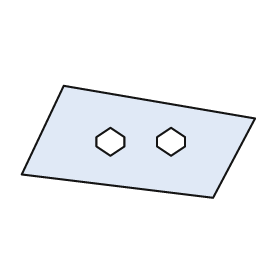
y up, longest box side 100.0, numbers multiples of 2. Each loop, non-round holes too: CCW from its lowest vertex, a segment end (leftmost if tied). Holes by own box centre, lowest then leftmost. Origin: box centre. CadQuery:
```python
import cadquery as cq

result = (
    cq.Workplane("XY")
    .moveTo(32.0, -24.0)
    .lineTo(50.0, 10.0)
    .lineTo(-32.0, 24.0)
    .lineTo(-50.0, -14.0)
    .close()
    .moveTo(-12.0, -6.0)
    .lineTo(-6.0, -2.0)
    .lineTo(-6.0, 2.0)
    .lineTo(-12.0, 6.0)
    .lineTo(-18.0, 2.0)
    .lineTo(-18.0, -2.0)
    .close()
    .moveTo(14.0, -6.0)
    .lineTo(20.0, -2.0)
    .lineTo(20.0, 2.0)
    .lineTo(14.0, 6.0)
    .lineTo(8.0, 2.0)
    .lineTo(8.0, -2.0)
    .close()
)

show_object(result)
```